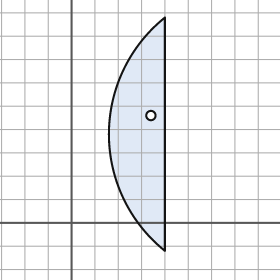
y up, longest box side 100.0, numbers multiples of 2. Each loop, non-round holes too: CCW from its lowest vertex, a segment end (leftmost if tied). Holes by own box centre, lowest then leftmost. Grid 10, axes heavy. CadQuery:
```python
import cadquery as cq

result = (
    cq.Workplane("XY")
    .moveTo(40.0, -12.0)
    .lineTo(40.0, 88.0)
    .threePointArc((16.0, 38.0), (40.0, -12.0))
    .close()
    .moveTo(34.0, 46.0)
    .circle(2.0)
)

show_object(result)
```